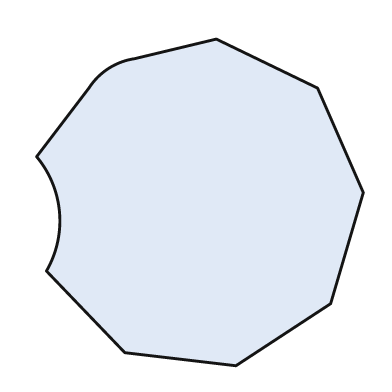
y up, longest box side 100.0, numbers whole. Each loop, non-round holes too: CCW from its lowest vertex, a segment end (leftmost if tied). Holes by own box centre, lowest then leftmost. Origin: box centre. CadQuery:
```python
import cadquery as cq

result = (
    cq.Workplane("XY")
    .moveTo(11.0, -50.0)
    .lineTo(40.0, -31.0)
    .lineTo(50.0, 3.0)
    .lineTo(36.0, 35.0)
    .lineTo(5.0, 50.0)
    .lineTo(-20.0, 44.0)
    .threePointArc((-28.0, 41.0), (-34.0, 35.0))
    .lineTo(-50.0, 14.0)
    .threePointArc((-43.0, -3.0), (-47.0, -21.0))
    .lineTo(-23.0, -46.0)
    .close()
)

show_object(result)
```